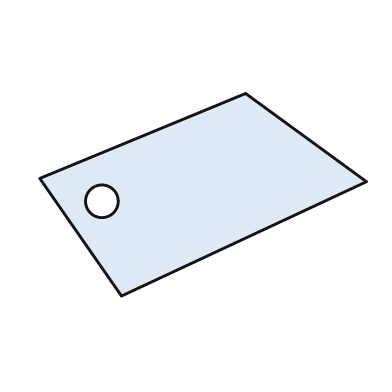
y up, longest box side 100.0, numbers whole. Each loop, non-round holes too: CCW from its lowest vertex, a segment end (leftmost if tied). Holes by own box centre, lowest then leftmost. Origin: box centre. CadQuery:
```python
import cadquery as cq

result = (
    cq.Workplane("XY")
    .moveTo(-25.0, -31.0)
    .lineTo(50.0, 4.0)
    .lineTo(13.0, 31.0)
    .lineTo(-50.0, 5.0)
    .close()
    .moveTo(-31.0, -2.0)
    .circle(5.0)
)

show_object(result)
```